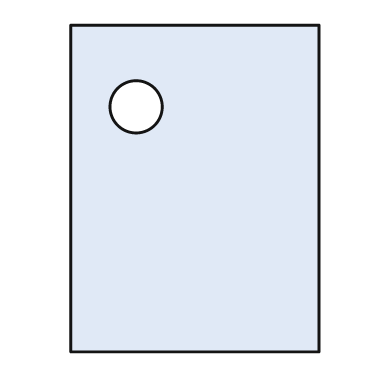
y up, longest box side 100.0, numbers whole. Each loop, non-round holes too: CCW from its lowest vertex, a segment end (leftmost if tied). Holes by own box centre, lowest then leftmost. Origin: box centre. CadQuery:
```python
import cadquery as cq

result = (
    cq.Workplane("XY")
    .moveTo(-38.0, -50.0)
    .lineTo(38.0, -50.0)
    .lineTo(38.0, 50.0)
    .lineTo(-38.0, 50.0)
    .close()
    .moveTo(-18.0, 25.0)
    .circle(8.0)
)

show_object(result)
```